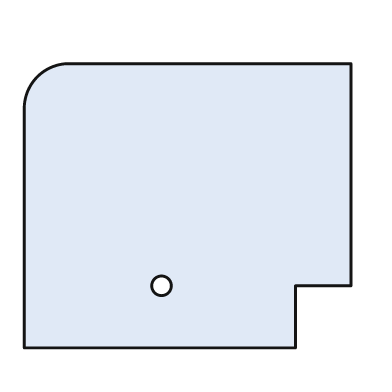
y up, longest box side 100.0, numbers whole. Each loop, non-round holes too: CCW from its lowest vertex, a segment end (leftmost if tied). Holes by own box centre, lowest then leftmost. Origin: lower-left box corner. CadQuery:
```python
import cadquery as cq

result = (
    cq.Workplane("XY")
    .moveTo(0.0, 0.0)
    .lineTo(83.0, 0.0)
    .lineTo(83.0, 19.0)
    .lineTo(100.0, 19.0)
    .lineTo(100.0, 87.0)
    .lineTo(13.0, 87.0)
    .threePointArc((4.0, 83.0), (0.0, 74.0))
    .close()
    .moveTo(42.0, 19.0)
    .circle(3.0)
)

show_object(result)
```